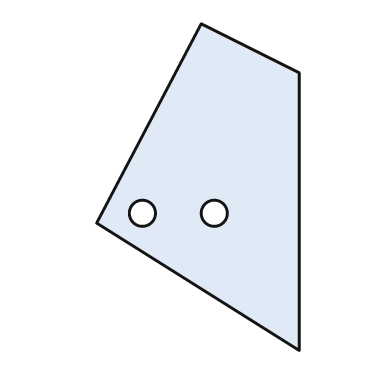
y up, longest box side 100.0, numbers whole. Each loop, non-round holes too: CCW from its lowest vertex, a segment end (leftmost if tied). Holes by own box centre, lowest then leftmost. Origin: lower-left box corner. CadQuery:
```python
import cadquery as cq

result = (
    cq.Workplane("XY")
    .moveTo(62.0, 0.0)
    .lineTo(62.0, 85.0)
    .lineTo(32.0, 100.0)
    .lineTo(0.0, 39.0)
    .close()
    .moveTo(14.0, 42.0)
    .circle(4.0)
    .moveTo(36.0, 42.0)
    .circle(4.0)
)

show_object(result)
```